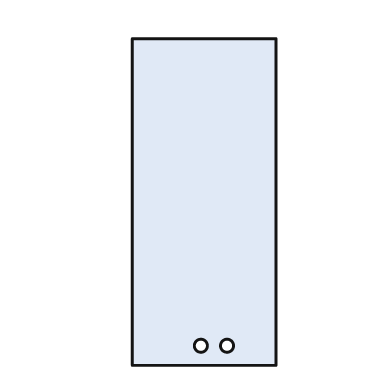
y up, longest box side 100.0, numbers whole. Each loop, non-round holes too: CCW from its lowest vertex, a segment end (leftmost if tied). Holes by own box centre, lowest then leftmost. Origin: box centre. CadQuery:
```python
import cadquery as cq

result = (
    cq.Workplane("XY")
    .moveTo(-22.0, -50.0)
    .lineTo(22.0, -50.0)
    .lineTo(22.0, 50.0)
    .lineTo(-22.0, 50.0)
    .close()
    .moveTo(-1.0, -44.0)
    .circle(2.0)
    .moveTo(7.0, -44.0)
    .circle(2.0)
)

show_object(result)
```